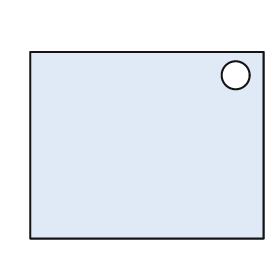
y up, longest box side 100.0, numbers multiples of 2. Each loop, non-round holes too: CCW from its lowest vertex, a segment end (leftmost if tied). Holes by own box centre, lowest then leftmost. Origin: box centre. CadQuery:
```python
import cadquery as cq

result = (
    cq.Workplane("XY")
    .moveTo(-50.0, -40.0)
    .lineTo(50.0, -40.0)
    .lineTo(50.0, 40.0)
    .lineTo(-50.0, 40.0)
    .close()
    .moveTo(38.0, 30.0)
    .circle(6.0)
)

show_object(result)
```